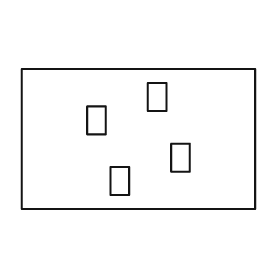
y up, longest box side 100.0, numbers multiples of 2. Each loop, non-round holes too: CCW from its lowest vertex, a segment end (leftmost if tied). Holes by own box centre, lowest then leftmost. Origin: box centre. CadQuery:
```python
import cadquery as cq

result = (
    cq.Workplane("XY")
    .moveTo(-50.0, -30.0)
    .lineTo(50.0, -30.0)
    .lineTo(50.0, 30.0)
    .lineTo(-50.0, 30.0)
    .close()
    .moveTo(-12.0, -24.0)
    .lineTo(-4.0, -24.0)
    .lineTo(-4.0, -12.0)
    .lineTo(-12.0, -12.0)
    .close()
    .moveTo(14.0, -14.0)
    .lineTo(22.0, -14.0)
    .lineTo(22.0, -2.0)
    .lineTo(14.0, -2.0)
    .close()
    .moveTo(-22.0, 2.0)
    .lineTo(-14.0, 2.0)
    .lineTo(-14.0, 14.0)
    .lineTo(-22.0, 14.0)
    .close()
    .moveTo(4.0, 12.0)
    .lineTo(12.0, 12.0)
    .lineTo(12.0, 24.0)
    .lineTo(4.0, 24.0)
    .close()
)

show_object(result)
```